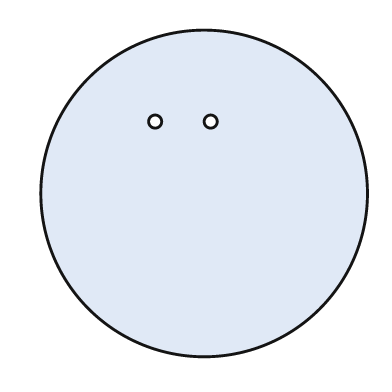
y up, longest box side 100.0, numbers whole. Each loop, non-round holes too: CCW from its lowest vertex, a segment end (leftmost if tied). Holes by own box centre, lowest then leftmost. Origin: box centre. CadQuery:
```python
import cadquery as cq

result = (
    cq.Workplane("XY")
    .moveTo(0.0, 0.0)
    .circle(50.0)
    .moveTo(-15.0, 22.0)
    .circle(2.0)
    .moveTo(2.0, 22.0)
    .circle(2.0)
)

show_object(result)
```